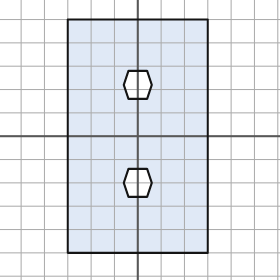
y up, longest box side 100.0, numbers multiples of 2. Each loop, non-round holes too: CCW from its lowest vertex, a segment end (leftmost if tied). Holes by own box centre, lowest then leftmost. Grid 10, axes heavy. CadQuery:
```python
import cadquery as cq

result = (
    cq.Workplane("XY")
    .moveTo(-30.0, -50.0)
    .lineTo(30.0, -50.0)
    .lineTo(30.0, 50.0)
    .lineTo(-30.0, 50.0)
    .close()
    .moveTo(-4.0, -26.0)
    .lineTo(4.0, -26.0)
    .lineTo(6.0, -20.0)
    .lineTo(4.0, -14.0)
    .lineTo(-4.0, -14.0)
    .lineTo(-6.0, -20.0)
    .close()
    .moveTo(-4.0, 16.0)
    .lineTo(4.0, 16.0)
    .lineTo(6.0, 22.0)
    .lineTo(4.0, 28.0)
    .lineTo(-4.0, 28.0)
    .lineTo(-6.0, 22.0)
    .close()
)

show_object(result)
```